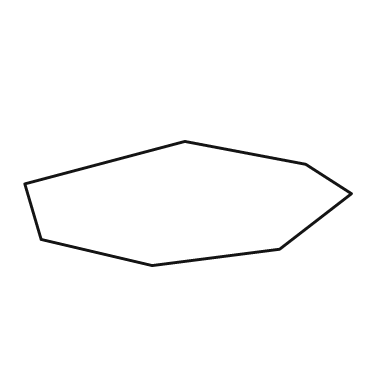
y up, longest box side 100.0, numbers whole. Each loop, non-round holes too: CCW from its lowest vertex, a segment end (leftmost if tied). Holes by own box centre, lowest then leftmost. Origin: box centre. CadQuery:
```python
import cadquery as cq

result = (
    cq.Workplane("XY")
    .moveTo(-11.0, -19.0)
    .lineTo(28.0, -14.0)
    .lineTo(50.0, 3.0)
    .lineTo(36.0, 12.0)
    .lineTo(-1.0, 19.0)
    .lineTo(-50.0, 6.0)
    .lineTo(-45.0, -11.0)
    .close()
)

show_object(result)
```